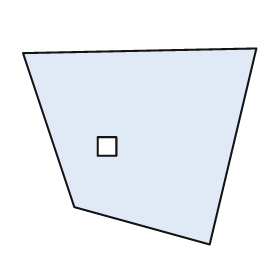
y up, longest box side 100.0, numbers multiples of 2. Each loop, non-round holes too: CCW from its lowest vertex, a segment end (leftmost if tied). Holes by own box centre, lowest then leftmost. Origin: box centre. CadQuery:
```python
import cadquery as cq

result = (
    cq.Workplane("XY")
    .moveTo(30.0, -42.0)
    .lineTo(50.0, 42.0)
    .lineTo(-50.0, 40.0)
    .lineTo(-28.0, -26.0)
    .close()
    .moveTo(-18.0, -4.0)
    .lineTo(-10.0, -4.0)
    .lineTo(-10.0, 4.0)
    .lineTo(-18.0, 4.0)
    .close()
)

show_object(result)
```